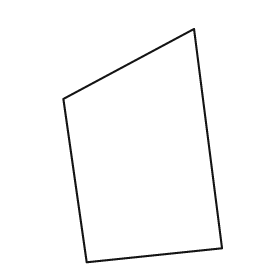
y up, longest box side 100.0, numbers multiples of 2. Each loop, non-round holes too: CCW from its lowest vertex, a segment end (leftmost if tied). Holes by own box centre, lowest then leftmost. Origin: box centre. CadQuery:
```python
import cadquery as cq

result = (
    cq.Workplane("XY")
    .moveTo(-24.0, -50.0)
    .lineTo(34.0, -44.0)
    .lineTo(22.0, 50.0)
    .lineTo(-34.0, 20.0)
    .close()
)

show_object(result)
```